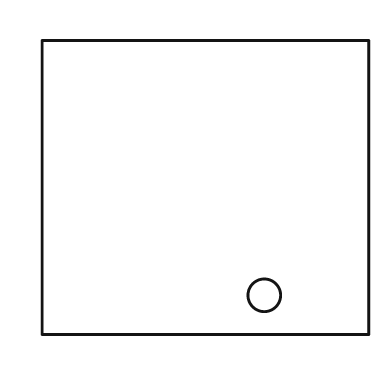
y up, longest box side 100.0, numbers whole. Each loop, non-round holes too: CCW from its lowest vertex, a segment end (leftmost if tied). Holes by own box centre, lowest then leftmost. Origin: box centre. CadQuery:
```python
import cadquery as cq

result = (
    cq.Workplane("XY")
    .moveTo(-50.0, -45.0)
    .lineTo(50.0, -45.0)
    .lineTo(50.0, 45.0)
    .lineTo(-50.0, 45.0)
    .close()
    .moveTo(18.0, -33.0)
    .circle(5.0)
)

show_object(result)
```